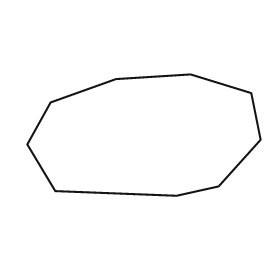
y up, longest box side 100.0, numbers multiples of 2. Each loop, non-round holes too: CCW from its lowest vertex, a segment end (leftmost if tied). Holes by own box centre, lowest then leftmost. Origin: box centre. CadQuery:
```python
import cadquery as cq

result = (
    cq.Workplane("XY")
    .moveTo(14.0, -26.0)
    .lineTo(32.0, -22.0)
    .lineTo(50.0, -2.0)
    .lineTo(46.0, 18.0)
    .lineTo(20.0, 26.0)
    .lineTo(-12.0, 24.0)
    .lineTo(-40.0, 14.0)
    .lineTo(-50.0, -4.0)
    .lineTo(-38.0, -24.0)
    .close()
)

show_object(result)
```